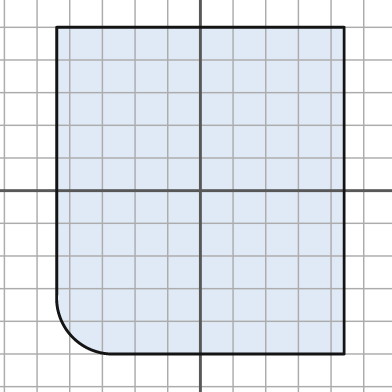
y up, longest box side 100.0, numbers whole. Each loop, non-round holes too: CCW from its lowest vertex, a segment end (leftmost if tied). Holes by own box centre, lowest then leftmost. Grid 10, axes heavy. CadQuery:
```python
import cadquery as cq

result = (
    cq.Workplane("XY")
    .moveTo(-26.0, -50.0)
    .lineTo(44.0, -50.0)
    .lineTo(44.0, 50.0)
    .lineTo(-44.0, 50.0)
    .lineTo(-44.0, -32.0)
    .threePointArc((-39.0, -45.0), (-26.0, -50.0))
    .close()
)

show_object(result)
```